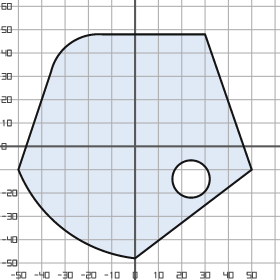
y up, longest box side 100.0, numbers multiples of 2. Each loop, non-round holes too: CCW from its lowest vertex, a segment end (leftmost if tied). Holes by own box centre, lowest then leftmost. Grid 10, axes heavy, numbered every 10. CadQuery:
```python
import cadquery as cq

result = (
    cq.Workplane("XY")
    .moveTo(0.0, -48.0)
    .lineTo(50.0, -10.0)
    .lineTo(30.0, 48.0)
    .lineTo(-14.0, 48.0)
    .threePointArc((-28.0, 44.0), (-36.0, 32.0))
    .lineTo(-50.0, -10.0)
    .threePointArc((-30.0, -36.0), (0.0, -48.0))
    .close()
    .moveTo(24.0, -14.0)
    .circle(8.0)
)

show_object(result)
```